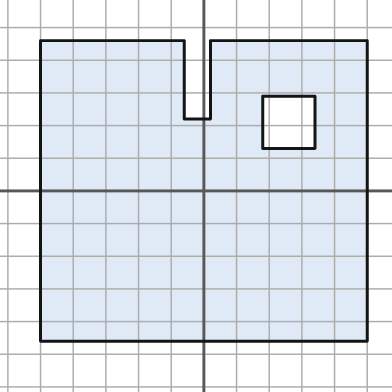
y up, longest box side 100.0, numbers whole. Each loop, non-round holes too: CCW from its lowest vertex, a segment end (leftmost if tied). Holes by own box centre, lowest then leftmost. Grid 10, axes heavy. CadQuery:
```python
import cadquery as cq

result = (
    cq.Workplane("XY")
    .moveTo(-50.0, -46.0)
    .lineTo(50.0, -46.0)
    .lineTo(50.0, 46.0)
    .lineTo(2.0, 46.0)
    .lineTo(2.0, 22.0)
    .lineTo(-6.0, 22.0)
    .lineTo(-6.0, 46.0)
    .lineTo(-50.0, 46.0)
    .close()
    .moveTo(18.0, 13.0)
    .lineTo(34.0, 13.0)
    .lineTo(34.0, 29.0)
    .lineTo(18.0, 29.0)
    .close()
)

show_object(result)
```